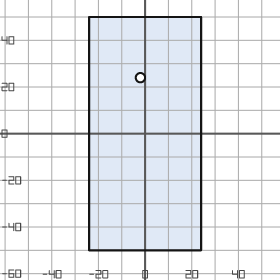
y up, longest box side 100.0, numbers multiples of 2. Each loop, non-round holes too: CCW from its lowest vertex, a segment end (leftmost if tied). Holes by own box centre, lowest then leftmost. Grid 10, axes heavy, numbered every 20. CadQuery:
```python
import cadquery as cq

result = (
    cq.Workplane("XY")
    .moveTo(-24.0, -50.0)
    .lineTo(24.0, -50.0)
    .lineTo(24.0, 50.0)
    .lineTo(-24.0, 50.0)
    .close()
    .moveTo(-2.0, 24.0)
    .circle(2.0)
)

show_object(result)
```